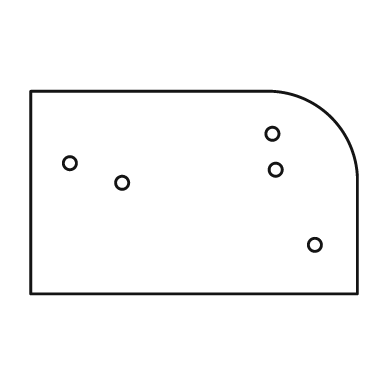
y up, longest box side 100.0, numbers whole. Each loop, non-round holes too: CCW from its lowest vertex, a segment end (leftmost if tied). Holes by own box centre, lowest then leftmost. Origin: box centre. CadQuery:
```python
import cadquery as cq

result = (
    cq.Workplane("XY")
    .moveTo(-50.0, -31.0)
    .lineTo(50.0, -31.0)
    .lineTo(50.0, 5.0)
    .threePointArc((42.0, 23.0), (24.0, 31.0))
    .lineTo(-50.0, 31.0)
    .close()
    .moveTo(37.0, -16.0)
    .circle(2.0)
    .moveTo(-22.0, 3.0)
    .circle(2.0)
    .moveTo(25.0, 7.0)
    .circle(2.0)
    .moveTo(-38.0, 9.0)
    .circle(2.0)
    .moveTo(24.0, 18.0)
    .circle(2.0)
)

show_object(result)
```